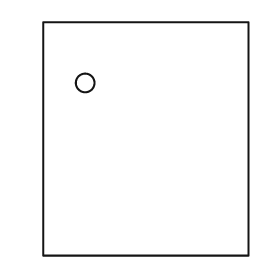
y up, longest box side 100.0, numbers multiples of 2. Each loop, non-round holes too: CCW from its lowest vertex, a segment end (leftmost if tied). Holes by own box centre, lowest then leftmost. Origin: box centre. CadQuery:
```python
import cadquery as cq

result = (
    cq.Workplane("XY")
    .moveTo(-44.0, -50.0)
    .lineTo(44.0, -50.0)
    .lineTo(44.0, 50.0)
    .lineTo(-44.0, 50.0)
    .close()
    .moveTo(-26.0, 24.0)
    .circle(4.0)
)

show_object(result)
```